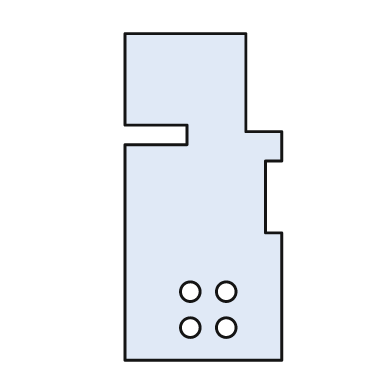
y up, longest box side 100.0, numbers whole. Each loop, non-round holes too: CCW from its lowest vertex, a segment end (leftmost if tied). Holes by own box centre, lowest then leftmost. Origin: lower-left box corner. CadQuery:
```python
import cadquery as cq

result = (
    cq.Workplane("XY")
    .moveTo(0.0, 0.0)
    .lineTo(48.0, 0.0)
    .lineTo(48.0, 39.0)
    .lineTo(43.0, 39.0)
    .lineTo(43.0, 61.0)
    .lineTo(48.0, 61.0)
    .lineTo(48.0, 70.0)
    .lineTo(37.0, 70.0)
    .lineTo(37.0, 100.0)
    .lineTo(0.0, 100.0)
    .lineTo(0.0, 72.0)
    .lineTo(19.0, 72.0)
    .lineTo(19.0, 66.0)
    .lineTo(0.0, 66.0)
    .close()
    .moveTo(20.0, 10.0)
    .circle(3.0)
    .moveTo(31.0, 10.0)
    .circle(3.0)
    .moveTo(20.0, 21.0)
    .circle(3.0)
    .moveTo(31.0, 21.0)
    .circle(3.0)
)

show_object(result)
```